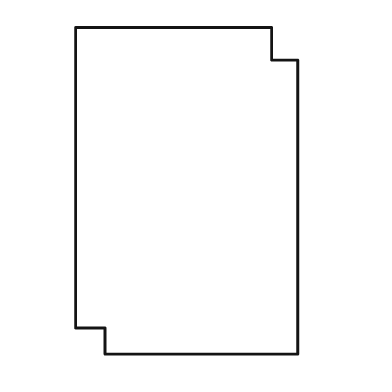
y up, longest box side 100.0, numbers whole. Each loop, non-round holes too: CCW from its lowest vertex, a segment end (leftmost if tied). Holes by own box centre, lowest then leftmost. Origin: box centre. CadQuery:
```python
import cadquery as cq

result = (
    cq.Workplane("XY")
    .moveTo(-25.0, -50.0)
    .lineTo(34.0, -50.0)
    .lineTo(34.0, 40.0)
    .lineTo(26.0, 40.0)
    .lineTo(26.0, 50.0)
    .lineTo(-34.0, 50.0)
    .lineTo(-34.0, -42.0)
    .lineTo(-25.0, -42.0)
    .close()
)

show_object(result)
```